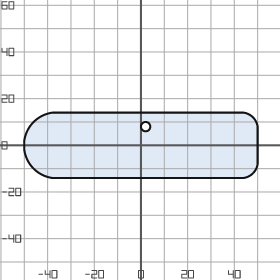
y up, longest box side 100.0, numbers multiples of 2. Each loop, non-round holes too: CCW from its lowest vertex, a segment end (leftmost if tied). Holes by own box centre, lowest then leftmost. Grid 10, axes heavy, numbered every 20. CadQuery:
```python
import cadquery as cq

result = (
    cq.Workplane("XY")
    .moveTo(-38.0, -14.0)
    .lineTo(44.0, -14.0)
    .threePointArc((48.0, -12.0), (50.0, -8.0))
    .lineTo(50.0, 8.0)
    .threePointArc((48.0, 12.0), (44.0, 14.0))
    .lineTo(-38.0, 14.0)
    .threePointArc((-46.0, 10.0), (-50.0, 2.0))
    .lineTo(-50.0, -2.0)
    .threePointArc((-46.0, -10.0), (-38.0, -14.0))
    .close()
    .moveTo(2.0, 8.0)
    .circle(2.0)
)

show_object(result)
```